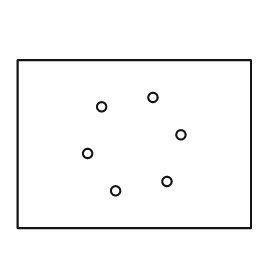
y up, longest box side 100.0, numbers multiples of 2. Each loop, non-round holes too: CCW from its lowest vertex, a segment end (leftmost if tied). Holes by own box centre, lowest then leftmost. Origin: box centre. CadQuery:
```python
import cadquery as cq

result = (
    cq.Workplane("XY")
    .moveTo(-50.0, -36.0)
    .lineTo(50.0, -36.0)
    .lineTo(50.0, 36.0)
    .lineTo(-50.0, 36.0)
    .close()
    .moveTo(-8.0, -20.0)
    .circle(2.0)
    .moveTo(14.0, -16.0)
    .circle(2.0)
    .moveTo(-20.0, -4.0)
    .circle(2.0)
    .moveTo(20.0, 4.0)
    .circle(2.0)
    .moveTo(-14.0, 16.0)
    .circle(2.0)
    .moveTo(8.0, 20.0)
    .circle(2.0)
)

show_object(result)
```